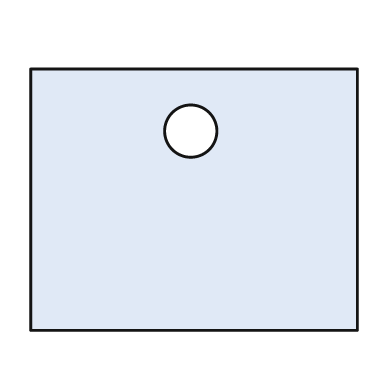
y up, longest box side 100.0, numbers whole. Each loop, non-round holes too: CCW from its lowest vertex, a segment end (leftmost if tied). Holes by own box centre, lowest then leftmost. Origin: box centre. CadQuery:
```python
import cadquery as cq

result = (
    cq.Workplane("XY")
    .moveTo(-50.0, -40.0)
    .lineTo(50.0, -40.0)
    .lineTo(50.0, 40.0)
    .lineTo(-50.0, 40.0)
    .close()
    .moveTo(-1.0, 21.0)
    .circle(8.0)
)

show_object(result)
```